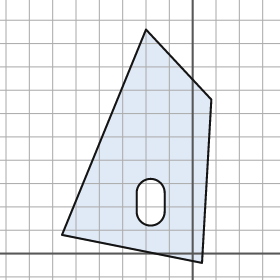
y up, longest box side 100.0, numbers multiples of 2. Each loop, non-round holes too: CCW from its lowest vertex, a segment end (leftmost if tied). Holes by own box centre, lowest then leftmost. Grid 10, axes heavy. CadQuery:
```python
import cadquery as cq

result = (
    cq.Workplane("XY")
    .moveTo(4.0, -4.0)
    .lineTo(8.0, 66.0)
    .lineTo(-20.0, 96.0)
    .lineTo(-56.0, 8.0)
    .close()
    .moveTo(-24.0, 18.0)
    .threePointArc((-18.0, 12.0), (-12.0, 18.0))
    .lineTo(-12.0, 26.0)
    .threePointArc((-18.0, 32.0), (-24.0, 26.0))
    .close()
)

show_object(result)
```